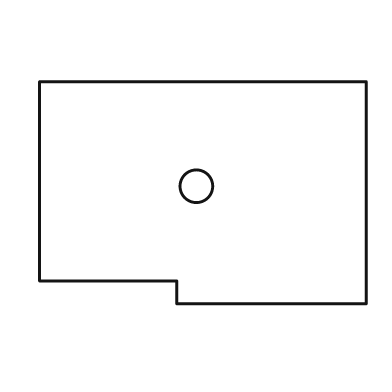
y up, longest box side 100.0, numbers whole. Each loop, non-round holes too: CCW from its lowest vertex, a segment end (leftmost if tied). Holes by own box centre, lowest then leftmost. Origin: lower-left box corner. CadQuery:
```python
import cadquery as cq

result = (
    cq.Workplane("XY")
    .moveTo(42.0, 0.0)
    .lineTo(100.0, 0.0)
    .lineTo(100.0, 68.0)
    .lineTo(0.0, 68.0)
    .lineTo(0.0, 7.0)
    .lineTo(42.0, 7.0)
    .close()
    .moveTo(48.0, 36.0)
    .circle(5.0)
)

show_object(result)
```